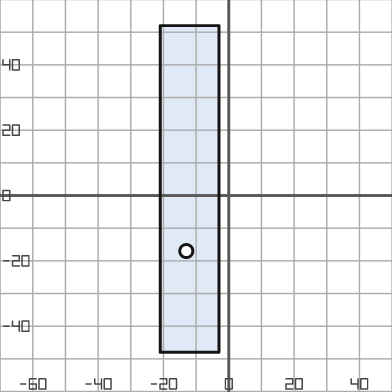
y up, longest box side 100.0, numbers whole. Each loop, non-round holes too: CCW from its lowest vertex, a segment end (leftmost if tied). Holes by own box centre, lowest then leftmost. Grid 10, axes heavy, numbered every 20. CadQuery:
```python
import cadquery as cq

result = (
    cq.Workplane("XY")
    .moveTo(-21.0, -48.0)
    .lineTo(-3.0, -48.0)
    .lineTo(-3.0, 52.0)
    .lineTo(-21.0, 52.0)
    .close()
    .moveTo(-13.0, -17.0)
    .circle(2.0)
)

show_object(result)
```